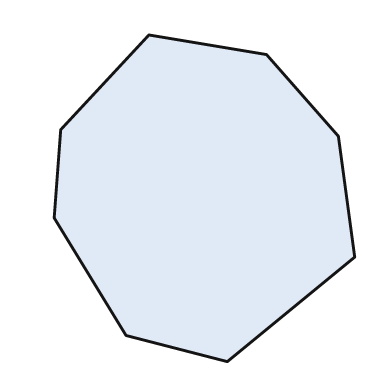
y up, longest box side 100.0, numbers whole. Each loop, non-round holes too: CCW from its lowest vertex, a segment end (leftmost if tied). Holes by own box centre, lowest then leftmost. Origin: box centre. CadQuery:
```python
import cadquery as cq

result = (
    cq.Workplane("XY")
    .moveTo(7.0, -50.0)
    .lineTo(46.0, -18.0)
    .lineTo(41.0, 19.0)
    .lineTo(19.0, 44.0)
    .lineTo(-17.0, 50.0)
    .lineTo(-44.0, 21.0)
    .lineTo(-46.0, -6.0)
    .lineTo(-24.0, -42.0)
    .close()
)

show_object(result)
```